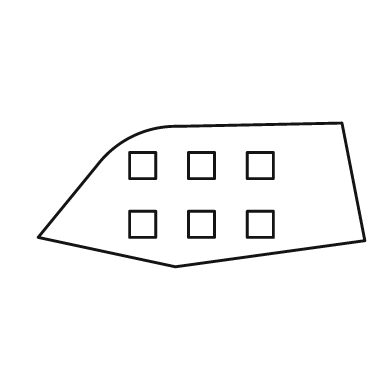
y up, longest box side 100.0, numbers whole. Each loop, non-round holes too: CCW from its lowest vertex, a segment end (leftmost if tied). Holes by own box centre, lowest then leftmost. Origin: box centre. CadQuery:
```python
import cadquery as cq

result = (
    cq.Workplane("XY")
    .moveTo(-8.0, -22.0)
    .lineTo(50.0, -14.0)
    .lineTo(43.0, 22.0)
    .lineTo(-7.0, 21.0)
    .threePointArc((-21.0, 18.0), (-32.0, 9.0))
    .lineTo(-50.0, -13.0)
    .close()
    .moveTo(-22.0, -13.0)
    .lineTo(-14.0, -13.0)
    .lineTo(-14.0, -5.0)
    .lineTo(-22.0, -5.0)
    .close()
    .moveTo(-4.0, -13.0)
    .lineTo(4.0, -13.0)
    .lineTo(4.0, -5.0)
    .lineTo(-4.0, -5.0)
    .close()
    .moveTo(14.0, -13.0)
    .lineTo(22.0, -13.0)
    .lineTo(22.0, -5.0)
    .lineTo(14.0, -5.0)
    .close()
    .moveTo(-22.0, 5.0)
    .lineTo(-14.0, 5.0)
    .lineTo(-14.0, 13.0)
    .lineTo(-22.0, 13.0)
    .close()
    .moveTo(-4.0, 5.0)
    .lineTo(4.0, 5.0)
    .lineTo(4.0, 13.0)
    .lineTo(-4.0, 13.0)
    .close()
    .moveTo(14.0, 5.0)
    .lineTo(22.0, 5.0)
    .lineTo(22.0, 13.0)
    .lineTo(14.0, 13.0)
    .close()
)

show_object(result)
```